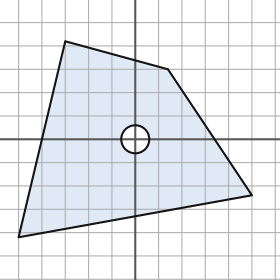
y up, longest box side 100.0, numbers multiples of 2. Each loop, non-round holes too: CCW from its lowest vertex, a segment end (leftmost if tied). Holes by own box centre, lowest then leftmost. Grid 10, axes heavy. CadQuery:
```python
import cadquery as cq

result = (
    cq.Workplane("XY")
    .moveTo(-50.0, -42.0)
    .lineTo(50.0, -24.0)
    .lineTo(14.0, 30.0)
    .lineTo(-30.0, 42.0)
    .close()
    .moveTo(0.0, 0.0)
    .circle(6.0)
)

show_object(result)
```